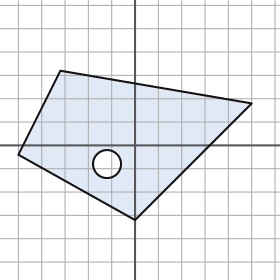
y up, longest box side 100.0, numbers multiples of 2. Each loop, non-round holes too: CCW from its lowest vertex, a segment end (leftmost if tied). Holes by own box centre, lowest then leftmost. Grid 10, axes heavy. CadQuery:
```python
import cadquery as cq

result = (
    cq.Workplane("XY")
    .moveTo(0.0, -32.0)
    .lineTo(50.0, 18.0)
    .lineTo(-32.0, 32.0)
    .lineTo(-50.0, -4.0)
    .close()
    .moveTo(-12.0, -8.0)
    .circle(6.0)
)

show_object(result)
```